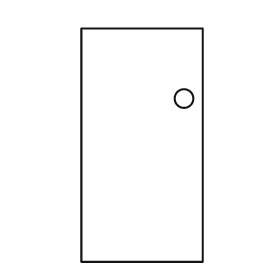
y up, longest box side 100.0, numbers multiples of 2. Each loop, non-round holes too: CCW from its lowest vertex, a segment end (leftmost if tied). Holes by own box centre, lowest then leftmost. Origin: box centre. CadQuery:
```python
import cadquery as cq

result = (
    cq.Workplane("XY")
    .moveTo(-26.0, -50.0)
    .lineTo(26.0, -50.0)
    .lineTo(26.0, 50.0)
    .lineTo(-26.0, 50.0)
    .close()
    .moveTo(18.0, 20.0)
    .circle(4.0)
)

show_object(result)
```